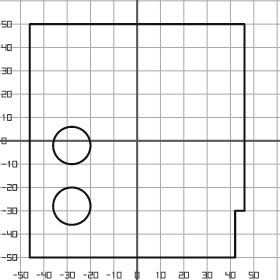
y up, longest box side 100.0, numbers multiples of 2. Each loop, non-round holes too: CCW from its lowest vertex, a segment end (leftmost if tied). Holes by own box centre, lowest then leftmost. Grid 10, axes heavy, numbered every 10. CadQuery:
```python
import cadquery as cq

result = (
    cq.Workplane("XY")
    .moveTo(-46.0, -50.0)
    .lineTo(42.0, -50.0)
    .lineTo(42.0, -30.0)
    .lineTo(46.0, -30.0)
    .lineTo(46.0, 50.0)
    .lineTo(-46.0, 50.0)
    .close()
    .moveTo(-28.0, -28.0)
    .circle(8.0)
    .moveTo(-28.0, -2.0)
    .circle(8.0)
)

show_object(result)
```